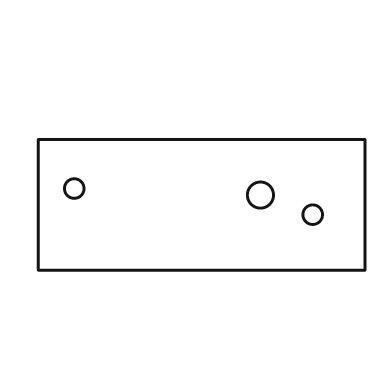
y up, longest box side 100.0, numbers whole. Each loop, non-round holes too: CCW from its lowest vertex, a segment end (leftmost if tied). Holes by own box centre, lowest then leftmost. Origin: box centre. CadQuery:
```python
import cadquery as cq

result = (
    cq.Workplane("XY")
    .moveTo(-50.0, -20.0)
    .lineTo(50.0, -20.0)
    .lineTo(50.0, 20.0)
    .lineTo(-50.0, 20.0)
    .close()
    .moveTo(34.0, -3.0)
    .circle(3.0)
    .moveTo(18.0, 3.0)
    .circle(4.0)
    .moveTo(-39.0, 5.0)
    .circle(3.0)
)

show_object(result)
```